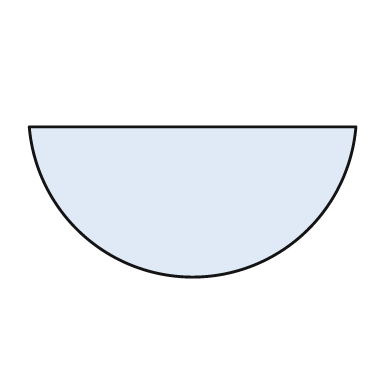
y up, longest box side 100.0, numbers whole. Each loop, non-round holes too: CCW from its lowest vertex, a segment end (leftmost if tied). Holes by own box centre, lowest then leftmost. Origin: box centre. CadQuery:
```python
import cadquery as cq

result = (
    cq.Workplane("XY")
    .moveTo(-50.0, 23.0)
    .threePointArc((0.0, -23.0), (50.0, 23.0))
    .close()
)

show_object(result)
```